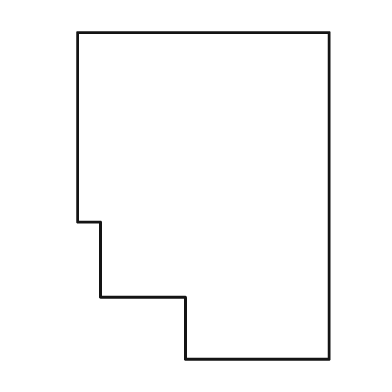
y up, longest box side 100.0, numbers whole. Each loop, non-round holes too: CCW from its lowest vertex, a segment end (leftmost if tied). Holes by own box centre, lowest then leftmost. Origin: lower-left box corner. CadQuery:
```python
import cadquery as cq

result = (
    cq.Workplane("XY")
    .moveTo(33.0, 0.0)
    .lineTo(77.0, 0.0)
    .lineTo(77.0, 100.0)
    .lineTo(0.0, 100.0)
    .lineTo(0.0, 42.0)
    .lineTo(7.0, 42.0)
    .lineTo(7.0, 19.0)
    .lineTo(33.0, 19.0)
    .close()
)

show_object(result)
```